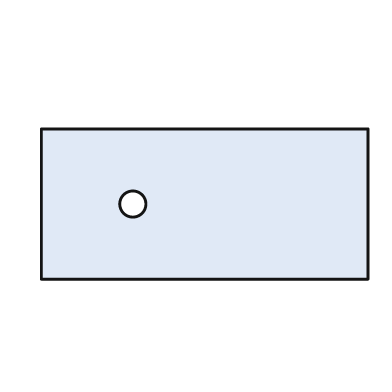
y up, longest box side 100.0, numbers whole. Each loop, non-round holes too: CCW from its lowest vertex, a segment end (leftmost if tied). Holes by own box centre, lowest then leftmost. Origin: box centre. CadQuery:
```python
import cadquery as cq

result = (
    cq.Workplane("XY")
    .moveTo(-50.0, -23.0)
    .lineTo(50.0, -23.0)
    .lineTo(50.0, 23.0)
    .lineTo(-50.0, 23.0)
    .close()
    .moveTo(-22.0, 0.0)
    .circle(4.0)
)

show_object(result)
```